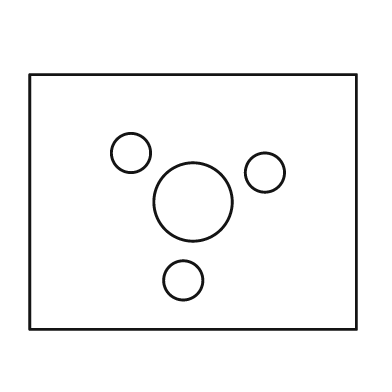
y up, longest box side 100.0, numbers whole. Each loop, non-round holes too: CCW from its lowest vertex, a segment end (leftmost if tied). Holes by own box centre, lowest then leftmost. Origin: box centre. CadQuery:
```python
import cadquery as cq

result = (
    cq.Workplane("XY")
    .moveTo(-50.0, -39.0)
    .lineTo(50.0, -39.0)
    .lineTo(50.0, 39.0)
    .lineTo(-50.0, 39.0)
    .close()
    .moveTo(-3.0, -24.0)
    .circle(6.0)
    .moveTo(0.0, 0.0)
    .circle(12.0)
    .moveTo(22.0, 9.0)
    .circle(6.0)
    .moveTo(-19.0, 15.0)
    .circle(6.0)
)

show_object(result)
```